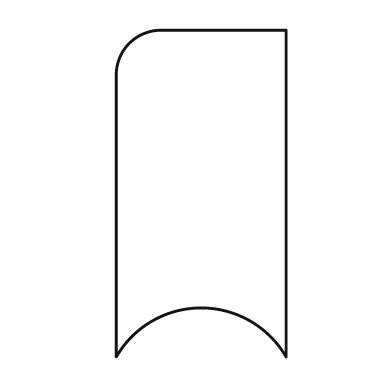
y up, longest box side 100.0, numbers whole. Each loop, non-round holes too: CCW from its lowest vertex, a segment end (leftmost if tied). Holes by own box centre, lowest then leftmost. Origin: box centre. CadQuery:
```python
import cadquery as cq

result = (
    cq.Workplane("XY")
    .moveTo(-26.0, -50.0)
    .threePointArc((0.0, -35.0), (26.0, -50.0))
    .lineTo(26.0, 50.0)
    .lineTo(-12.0, 50.0)
    .threePointArc((-22.0, 46.0), (-26.0, 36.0))
    .close()
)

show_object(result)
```